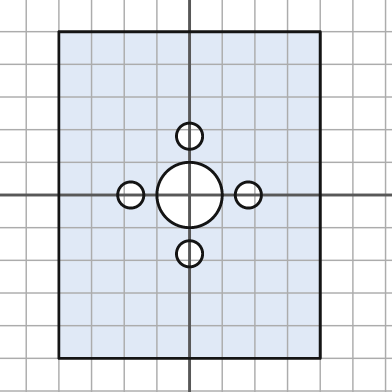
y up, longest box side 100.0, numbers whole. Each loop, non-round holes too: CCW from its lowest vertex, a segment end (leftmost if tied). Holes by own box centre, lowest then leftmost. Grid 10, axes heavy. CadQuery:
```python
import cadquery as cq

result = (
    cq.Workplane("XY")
    .moveTo(-40.0, -50.0)
    .lineTo(40.0, -50.0)
    .lineTo(40.0, 50.0)
    .lineTo(-40.0, 50.0)
    .close()
    .moveTo(0.0, -18.0)
    .circle(4.0)
    .moveTo(-18.0, 0.0)
    .circle(4.0)
    .moveTo(0.0, 0.0)
    .circle(10.0)
    .moveTo(18.0, 0.0)
    .circle(4.0)
    .moveTo(0.0, 18.0)
    .circle(4.0)
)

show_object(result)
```